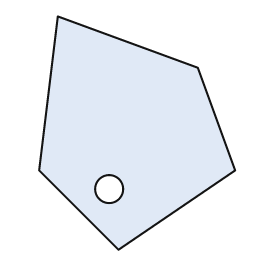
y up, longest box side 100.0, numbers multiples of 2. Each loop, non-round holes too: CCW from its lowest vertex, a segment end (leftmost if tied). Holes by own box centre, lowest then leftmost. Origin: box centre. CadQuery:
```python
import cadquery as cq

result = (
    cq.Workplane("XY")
    .moveTo(-8.0, -50.0)
    .lineTo(42.0, -16.0)
    .lineTo(26.0, 28.0)
    .lineTo(-34.0, 50.0)
    .lineTo(-42.0, -16.0)
    .close()
    .moveTo(-12.0, -24.0)
    .circle(6.0)
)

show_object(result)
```